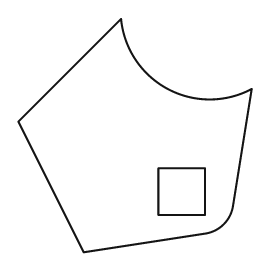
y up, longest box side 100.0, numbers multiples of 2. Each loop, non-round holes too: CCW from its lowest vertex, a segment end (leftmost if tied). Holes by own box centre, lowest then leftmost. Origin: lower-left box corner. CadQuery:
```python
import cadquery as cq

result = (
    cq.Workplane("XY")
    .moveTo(28.0, 0.0)
    .lineTo(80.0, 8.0)
    .threePointArc((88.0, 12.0), (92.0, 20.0))
    .lineTo(100.0, 70.0)
    .threePointArc((64.0, 70.0), (44.0, 100.0))
    .lineTo(0.0, 56.0)
    .close()
    .moveTo(60.0, 16.0)
    .lineTo(80.0, 16.0)
    .lineTo(80.0, 36.0)
    .lineTo(60.0, 36.0)
    .close()
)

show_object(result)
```